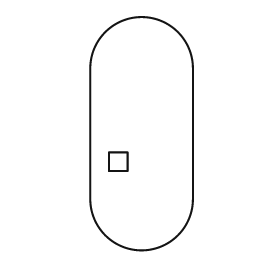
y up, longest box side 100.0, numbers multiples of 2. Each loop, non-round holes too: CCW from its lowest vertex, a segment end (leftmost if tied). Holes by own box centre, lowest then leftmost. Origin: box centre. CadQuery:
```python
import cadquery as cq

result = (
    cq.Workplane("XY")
    .moveTo(-22.0, -28.0)
    .threePointArc((0.0, -50.0), (22.0, -28.0))
    .lineTo(22.0, 28.0)
    .threePointArc((0.0, 50.0), (-22.0, 28.0))
    .close()
    .moveTo(-14.0, -16.0)
    .lineTo(-6.0, -16.0)
    .lineTo(-6.0, -8.0)
    .lineTo(-14.0, -8.0)
    .close()
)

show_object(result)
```